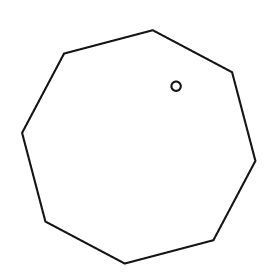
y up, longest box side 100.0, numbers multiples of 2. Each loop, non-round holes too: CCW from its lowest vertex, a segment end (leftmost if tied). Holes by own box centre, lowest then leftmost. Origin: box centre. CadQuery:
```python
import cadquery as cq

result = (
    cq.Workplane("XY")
    .moveTo(-6.0, -50.0)
    .lineTo(32.0, -40.0)
    .lineTo(50.0, -6.0)
    .lineTo(40.0, 32.0)
    .lineTo(6.0, 50.0)
    .lineTo(-32.0, 40.0)
    .lineTo(-50.0, 6.0)
    .lineTo(-40.0, -32.0)
    .close()
    .moveTo(16.0, 26.0)
    .circle(2.0)
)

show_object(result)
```